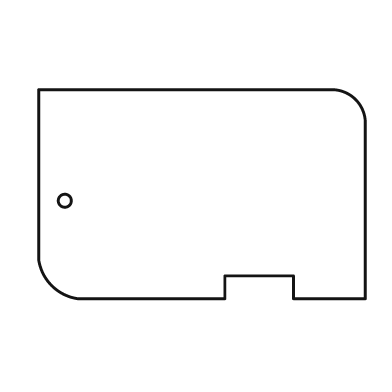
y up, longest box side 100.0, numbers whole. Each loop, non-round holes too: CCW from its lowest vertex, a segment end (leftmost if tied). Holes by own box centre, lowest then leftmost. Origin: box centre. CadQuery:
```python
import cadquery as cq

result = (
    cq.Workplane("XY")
    .moveTo(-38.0, -32.0)
    .lineTo(7.0, -32.0)
    .lineTo(7.0, -25.0)
    .lineTo(28.0, -25.0)
    .lineTo(28.0, -32.0)
    .lineTo(50.0, -32.0)
    .lineTo(50.0, 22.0)
    .threePointArc((47.0, 29.0), (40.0, 32.0))
    .lineTo(-50.0, 32.0)
    .lineTo(-50.0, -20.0)
    .threePointArc((-46.0, -28.0), (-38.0, -32.0))
    .close()
    .moveTo(-42.0, -2.0)
    .circle(2.0)
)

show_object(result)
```